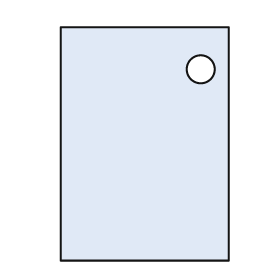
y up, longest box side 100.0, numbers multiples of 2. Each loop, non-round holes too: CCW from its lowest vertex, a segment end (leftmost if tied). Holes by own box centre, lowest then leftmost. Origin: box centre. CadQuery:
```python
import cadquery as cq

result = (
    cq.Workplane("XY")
    .moveTo(-36.0, -50.0)
    .lineTo(36.0, -50.0)
    .lineTo(36.0, 50.0)
    .lineTo(-36.0, 50.0)
    .close()
    .moveTo(24.0, 32.0)
    .circle(6.0)
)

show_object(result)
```